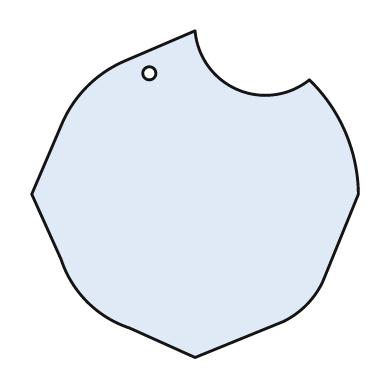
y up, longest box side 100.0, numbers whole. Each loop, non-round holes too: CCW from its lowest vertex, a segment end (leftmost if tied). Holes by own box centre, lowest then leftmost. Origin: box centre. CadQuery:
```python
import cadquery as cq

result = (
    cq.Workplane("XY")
    .moveTo(0.0, -50.0)
    .lineTo(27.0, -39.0)
    .threePointArc((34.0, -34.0), (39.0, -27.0))
    .lineTo(50.0, 0.0)
    .threePointArc((46.0, 19.0), (35.0, 35.0))
    .threePointArc((13.0, 32.0), (0.0, 50.0))
    .lineTo(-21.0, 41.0)
    .threePointArc((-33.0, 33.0), (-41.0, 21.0))
    .lineTo(-50.0, 0.0)
    .lineTo(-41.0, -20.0)
    .threePointArc((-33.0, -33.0), (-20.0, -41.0))
    .close()
    .moveTo(-14.0, 37.0)
    .circle(2.0)
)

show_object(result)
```